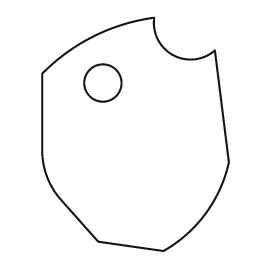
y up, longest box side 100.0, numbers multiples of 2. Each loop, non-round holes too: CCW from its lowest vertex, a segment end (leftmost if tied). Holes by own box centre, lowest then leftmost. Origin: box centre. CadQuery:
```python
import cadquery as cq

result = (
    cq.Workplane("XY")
    .moveTo(12.0, -50.0)
    .threePointArc((30.0, -34.0), (40.0, -12.0))
    .lineTo(34.0, 36.0)
    .threePointArc((16.0, 34.0), (8.0, 50.0))
    .threePointArc((-18.0, 42.0), (-40.0, 26.0))
    .lineTo(-40.0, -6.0)
    .threePointArc((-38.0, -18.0), (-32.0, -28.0))
    .lineTo(-16.0, -46.0)
    .close()
    .moveTo(-14.0, 22.0)
    .circle(8.0)
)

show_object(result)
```